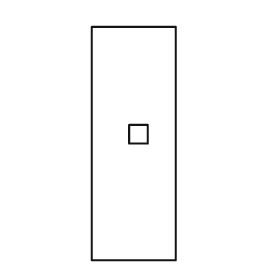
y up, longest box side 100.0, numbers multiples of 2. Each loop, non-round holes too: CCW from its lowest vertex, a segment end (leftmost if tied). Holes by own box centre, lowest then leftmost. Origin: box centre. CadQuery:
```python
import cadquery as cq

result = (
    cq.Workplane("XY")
    .moveTo(-18.0, -50.0)
    .lineTo(18.0, -50.0)
    .lineTo(18.0, 50.0)
    .lineTo(-18.0, 50.0)
    .close()
    .moveTo(-2.0, 0.0)
    .lineTo(6.0, 0.0)
    .lineTo(6.0, 8.0)
    .lineTo(-2.0, 8.0)
    .close()
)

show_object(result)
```